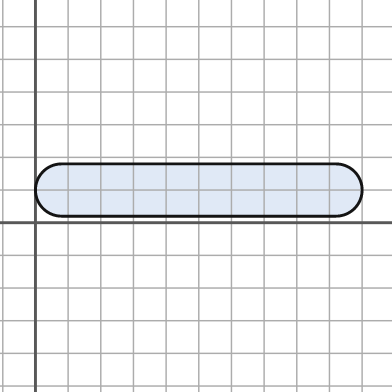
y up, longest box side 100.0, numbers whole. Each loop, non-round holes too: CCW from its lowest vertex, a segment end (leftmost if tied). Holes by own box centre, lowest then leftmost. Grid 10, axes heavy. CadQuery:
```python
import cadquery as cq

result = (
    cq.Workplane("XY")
    .moveTo(8.0, 2.0)
    .lineTo(92.0, 2.0)
    .threePointArc((100.0, 10.0), (92.0, 18.0))
    .lineTo(8.0, 18.0)
    .threePointArc((0.0, 10.0), (8.0, 2.0))
    .close()
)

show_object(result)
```